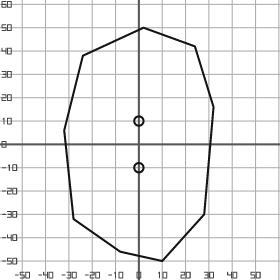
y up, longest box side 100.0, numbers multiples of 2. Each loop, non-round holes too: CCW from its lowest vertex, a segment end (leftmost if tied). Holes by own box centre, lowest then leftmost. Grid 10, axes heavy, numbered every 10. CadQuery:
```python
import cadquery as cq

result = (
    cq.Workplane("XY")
    .moveTo(10.0, -50.0)
    .lineTo(28.0, -30.0)
    .lineTo(32.0, 16.0)
    .lineTo(24.0, 42.0)
    .lineTo(2.0, 50.0)
    .lineTo(-24.0, 38.0)
    .lineTo(-32.0, 6.0)
    .lineTo(-28.0, -32.0)
    .lineTo(-8.0, -46.0)
    .close()
    .moveTo(0.0, -10.0)
    .circle(2.0)
    .moveTo(0.0, 10.0)
    .circle(2.0)
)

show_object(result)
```